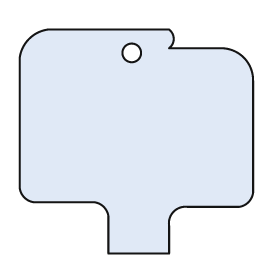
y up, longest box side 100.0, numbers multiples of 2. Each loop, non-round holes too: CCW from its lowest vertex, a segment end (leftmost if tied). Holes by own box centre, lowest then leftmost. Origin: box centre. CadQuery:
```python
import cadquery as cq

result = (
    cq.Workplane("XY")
    .moveTo(-12.0, -48.0)
    .lineTo(14.0, -48.0)
    .lineTo(14.0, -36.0)
    .threePointArc((16.0, -30.0), (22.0, -28.0))
    .lineTo(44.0, -28.0)
    .threePointArc((48.0, -26.0), (50.0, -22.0))
    .lineTo(50.0, 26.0)
    .threePointArc((46.0, 36.0), (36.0, 40.0))
    .lineTo(14.0, 40.0)
    .threePointArc((16.0, 44.0), (14.0, 48.0))
    .lineTo(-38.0, 48.0)
    .threePointArc((-46.0, 44.0), (-50.0, 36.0))
    .lineTo(-50.0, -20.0)
    .threePointArc((-48.0, -24.0), (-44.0, -26.0))
    .lineTo(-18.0, -26.0)
    .threePointArc((-14.0, -28.0), (-12.0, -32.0))
    .close()
    .moveTo(-2.0, 38.0)
    .circle(4.0)
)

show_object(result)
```